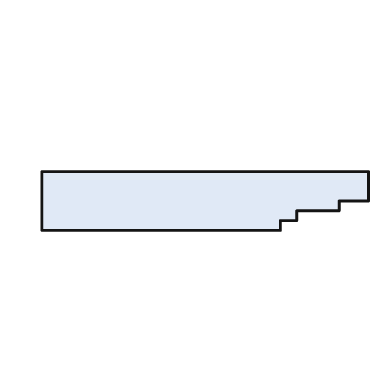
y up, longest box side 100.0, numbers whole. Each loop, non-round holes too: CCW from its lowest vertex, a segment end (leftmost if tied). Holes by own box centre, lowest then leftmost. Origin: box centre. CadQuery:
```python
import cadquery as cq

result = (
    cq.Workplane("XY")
    .moveTo(-50.0, -9.0)
    .lineTo(23.0, -9.0)
    .lineTo(23.0, -6.0)
    .lineTo(28.0, -6.0)
    .lineTo(28.0, -3.0)
    .lineTo(41.0, -3.0)
    .lineTo(41.0, 0.0)
    .lineTo(50.0, 0.0)
    .lineTo(50.0, 9.0)
    .lineTo(-50.0, 9.0)
    .close()
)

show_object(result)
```